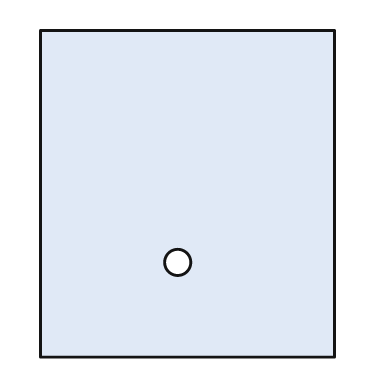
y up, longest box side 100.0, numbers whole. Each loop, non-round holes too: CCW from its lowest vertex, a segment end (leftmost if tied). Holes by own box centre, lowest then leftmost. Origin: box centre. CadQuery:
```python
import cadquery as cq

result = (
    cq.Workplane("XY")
    .moveTo(-45.0, -50.0)
    .lineTo(45.0, -50.0)
    .lineTo(45.0, 50.0)
    .lineTo(-45.0, 50.0)
    .close()
    .moveTo(-3.0, -21.0)
    .circle(4.0)
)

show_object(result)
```